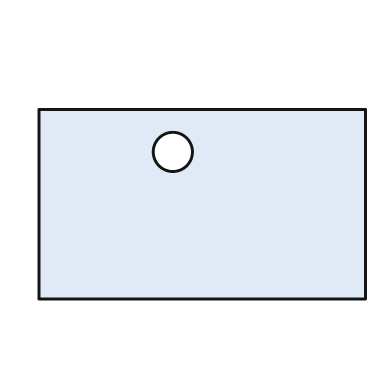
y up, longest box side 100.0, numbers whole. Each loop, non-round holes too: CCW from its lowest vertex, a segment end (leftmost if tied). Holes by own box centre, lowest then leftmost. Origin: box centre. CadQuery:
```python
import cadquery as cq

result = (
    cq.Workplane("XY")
    .moveTo(-50.0, -29.0)
    .lineTo(50.0, -29.0)
    .lineTo(50.0, 29.0)
    .lineTo(-50.0, 29.0)
    .close()
    .moveTo(-9.0, 16.0)
    .circle(6.0)
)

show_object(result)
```